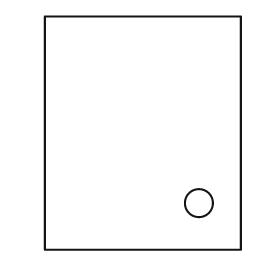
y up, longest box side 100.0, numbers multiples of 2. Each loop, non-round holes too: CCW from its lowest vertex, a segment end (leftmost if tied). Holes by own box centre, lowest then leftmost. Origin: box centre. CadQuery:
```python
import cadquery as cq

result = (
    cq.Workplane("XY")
    .moveTo(-42.0, -50.0)
    .lineTo(42.0, -50.0)
    .lineTo(42.0, 50.0)
    .lineTo(-42.0, 50.0)
    .close()
    .moveTo(24.0, -30.0)
    .circle(6.0)
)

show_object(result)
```